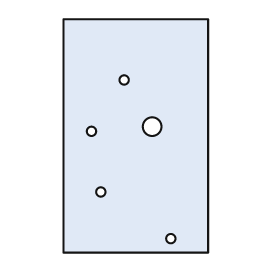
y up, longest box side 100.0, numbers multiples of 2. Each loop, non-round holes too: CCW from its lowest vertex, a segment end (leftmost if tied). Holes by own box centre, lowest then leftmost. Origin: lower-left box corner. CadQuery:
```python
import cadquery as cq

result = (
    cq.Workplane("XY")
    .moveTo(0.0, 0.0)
    .lineTo(62.0, 0.0)
    .lineTo(62.0, 100.0)
    .lineTo(0.0, 100.0)
    .close()
    .moveTo(46.0, 6.0)
    .circle(2.0)
    .moveTo(16.0, 26.0)
    .circle(2.0)
    .moveTo(12.0, 52.0)
    .circle(2.0)
    .moveTo(38.0, 54.0)
    .circle(4.0)
    .moveTo(26.0, 74.0)
    .circle(2.0)
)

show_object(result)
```